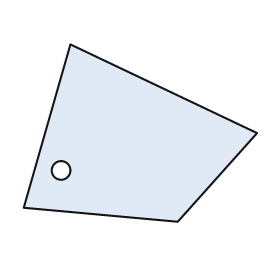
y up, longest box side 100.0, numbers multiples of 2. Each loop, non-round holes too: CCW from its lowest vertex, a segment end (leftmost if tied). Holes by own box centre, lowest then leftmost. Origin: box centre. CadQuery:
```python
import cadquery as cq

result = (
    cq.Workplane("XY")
    .moveTo(16.0, -38.0)
    .lineTo(50.0, 0.0)
    .lineTo(-30.0, 38.0)
    .lineTo(-50.0, -32.0)
    .close()
    .moveTo(-34.0, -16.0)
    .circle(4.0)
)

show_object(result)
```